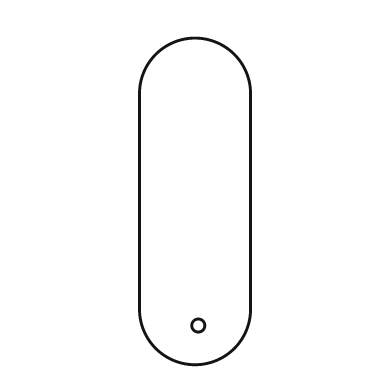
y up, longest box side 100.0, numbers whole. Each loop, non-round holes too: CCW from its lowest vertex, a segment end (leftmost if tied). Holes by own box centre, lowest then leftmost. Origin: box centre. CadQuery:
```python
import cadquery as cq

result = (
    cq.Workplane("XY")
    .moveTo(-17.0, -33.0)
    .threePointArc((0.0, -50.0), (17.0, -33.0))
    .lineTo(17.0, 33.0)
    .threePointArc((0.0, 50.0), (-17.0, 33.0))
    .close()
    .moveTo(1.0, -38.0)
    .circle(2.0)
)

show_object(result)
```